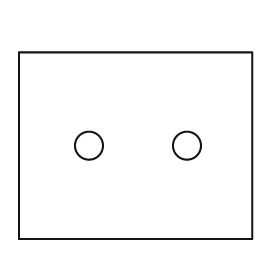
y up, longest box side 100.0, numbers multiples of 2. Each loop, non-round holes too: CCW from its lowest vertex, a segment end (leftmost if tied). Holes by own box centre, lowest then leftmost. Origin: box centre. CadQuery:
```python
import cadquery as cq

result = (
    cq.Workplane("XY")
    .moveTo(-50.0, -40.0)
    .lineTo(50.0, -40.0)
    .lineTo(50.0, 40.0)
    .lineTo(-50.0, 40.0)
    .close()
    .moveTo(-20.0, 0.0)
    .circle(6.0)
    .moveTo(22.0, 0.0)
    .circle(6.0)
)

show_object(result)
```